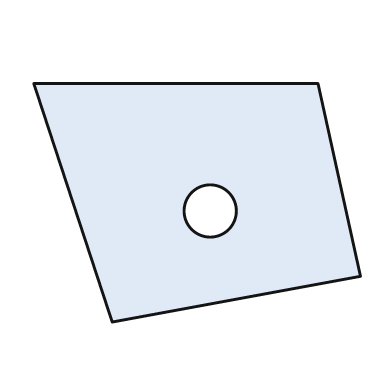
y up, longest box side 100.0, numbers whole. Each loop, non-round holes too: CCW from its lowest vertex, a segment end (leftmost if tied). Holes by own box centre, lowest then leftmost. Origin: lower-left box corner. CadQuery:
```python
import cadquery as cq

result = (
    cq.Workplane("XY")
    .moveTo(24.0, 0.0)
    .lineTo(100.0, 14.0)
    .lineTo(87.0, 73.0)
    .lineTo(0.0, 73.0)
    .close()
    .moveTo(54.0, 34.0)
    .circle(8.0)
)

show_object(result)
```